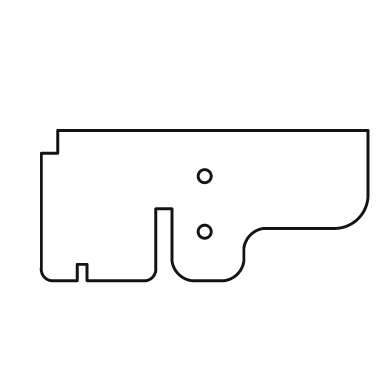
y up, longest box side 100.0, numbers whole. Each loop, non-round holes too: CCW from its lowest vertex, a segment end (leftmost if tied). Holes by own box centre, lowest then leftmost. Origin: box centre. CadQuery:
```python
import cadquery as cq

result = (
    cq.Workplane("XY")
    .moveTo(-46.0, -23.0)
    .lineTo(-39.0, -23.0)
    .lineTo(-39.0, -18.0)
    .lineTo(-36.0, -18.0)
    .lineTo(-36.0, -23.0)
    .lineTo(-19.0, -23.0)
    .threePointArc((-16.0, -22.0), (-15.0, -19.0))
    .lineTo(-15.0, -1.0)
    .lineTo(-10.0, -1.0)
    .lineTo(-10.0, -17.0)
    .threePointArc((-8.0, -21.0), (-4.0, -23.0))
    .lineTo(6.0, -23.0)
    .threePointArc((10.0, -21.0), (12.0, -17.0))
    .lineTo(12.0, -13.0)
    .threePointArc((14.0, -9.0), (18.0, -7.0))
    .lineTo(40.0, -7.0)
    .threePointArc((47.0, -4.0), (50.0, 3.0))
    .lineTo(50.0, 23.0)
    .lineTo(-45.0, 23.0)
    .lineTo(-45.0, 16.0)
    .lineTo(-50.0, 16.0)
    .lineTo(-50.0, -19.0)
    .threePointArc((-49.0, -22.0), (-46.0, -23.0))
    .close()
    .moveTo(0.0, -8.0)
    .circle(2.0)
    .moveTo(0.0, 9.0)
    .circle(2.0)
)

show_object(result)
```